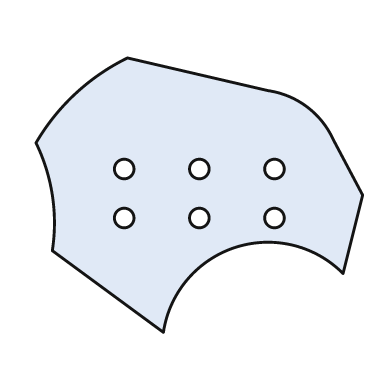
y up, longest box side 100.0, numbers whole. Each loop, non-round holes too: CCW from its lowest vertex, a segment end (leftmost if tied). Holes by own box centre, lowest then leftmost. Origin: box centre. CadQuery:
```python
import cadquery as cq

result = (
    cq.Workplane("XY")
    .moveTo(-11.0, -42.0)
    .threePointArc((11.0, -16.0), (44.0, -24.0))
    .lineTo(50.0, 0.0)
    .lineTo(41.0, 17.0)
    .threePointArc((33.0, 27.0), (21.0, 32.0))
    .lineTo(-22.0, 42.0)
    .threePointArc((-38.0, 31.0), (-50.0, 16.0))
    .threePointArc((-45.0, 0.0), (-45.0, -17.0))
    .close()
    .moveTo(-23.0, -7.0)
    .circle(3.0)
    .moveTo(0.0, -7.0)
    .circle(3.0)
    .moveTo(23.0, -7.0)
    .circle(3.0)
    .moveTo(-23.0, 8.0)
    .circle(3.0)
    .moveTo(0.0, 8.0)
    .circle(3.0)
    .moveTo(23.0, 8.0)
    .circle(3.0)
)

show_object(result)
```